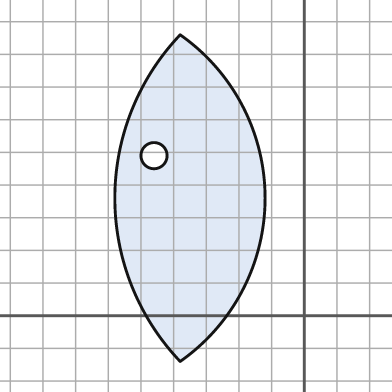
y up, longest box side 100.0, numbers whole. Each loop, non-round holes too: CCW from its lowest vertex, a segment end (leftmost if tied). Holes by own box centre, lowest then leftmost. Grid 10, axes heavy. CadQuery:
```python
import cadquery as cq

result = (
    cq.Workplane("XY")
    .moveTo(-38.0, -14.0)
    .threePointArc((-12.0, 36.0), (-38.0, 86.0))
    .threePointArc((-58.0, 36.0), (-38.0, -14.0))
    .close()
    .moveTo(-46.0, 49.0)
    .circle(4.0)
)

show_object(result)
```